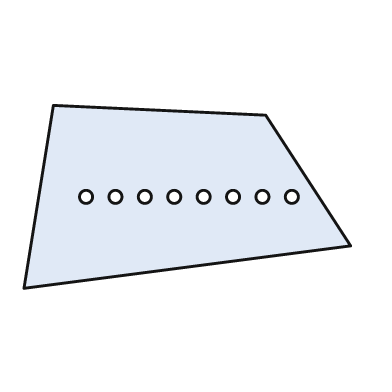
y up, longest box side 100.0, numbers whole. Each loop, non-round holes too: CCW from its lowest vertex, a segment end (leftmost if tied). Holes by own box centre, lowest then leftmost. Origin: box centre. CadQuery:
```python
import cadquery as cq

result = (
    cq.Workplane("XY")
    .moveTo(-50.0, -28.0)
    .lineTo(50.0, -15.0)
    .lineTo(24.0, 25.0)
    .lineTo(-41.0, 28.0)
    .close()
    .moveTo(-31.0, 0.0)
    .circle(2.0)
    .moveTo(-22.0, 0.0)
    .circle(2.0)
    .moveTo(-13.0, 0.0)
    .circle(2.0)
    .moveTo(-4.0, 0.0)
    .circle(2.0)
    .moveTo(5.0, 0.0)
    .circle(2.0)
    .moveTo(14.0, 0.0)
    .circle(2.0)
    .moveTo(23.0, 0.0)
    .circle(2.0)
    .moveTo(32.0, 0.0)
    .circle(2.0)
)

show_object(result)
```